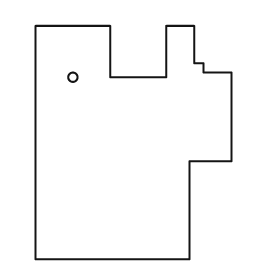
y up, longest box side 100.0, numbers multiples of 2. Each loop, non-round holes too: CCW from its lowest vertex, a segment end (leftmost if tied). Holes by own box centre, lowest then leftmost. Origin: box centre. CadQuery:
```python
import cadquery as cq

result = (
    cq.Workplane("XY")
    .moveTo(-42.0, -50.0)
    .lineTo(24.0, -50.0)
    .lineTo(24.0, -8.0)
    .lineTo(42.0, -8.0)
    .lineTo(42.0, 30.0)
    .lineTo(30.0, 30.0)
    .lineTo(30.0, 34.0)
    .lineTo(26.0, 34.0)
    .lineTo(26.0, 50.0)
    .lineTo(14.0, 50.0)
    .lineTo(14.0, 28.0)
    .lineTo(-10.0, 28.0)
    .lineTo(-10.0, 50.0)
    .lineTo(-42.0, 50.0)
    .close()
    .moveTo(-26.0, 28.0)
    .circle(2.0)
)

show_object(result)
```